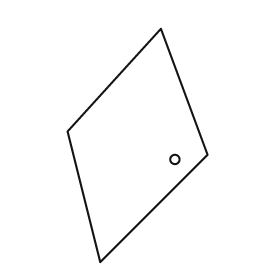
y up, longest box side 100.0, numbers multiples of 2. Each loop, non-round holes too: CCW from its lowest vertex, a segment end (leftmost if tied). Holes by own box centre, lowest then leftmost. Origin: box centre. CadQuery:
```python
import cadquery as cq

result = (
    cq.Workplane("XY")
    .moveTo(-16.0, -50.0)
    .lineTo(30.0, -4.0)
    .lineTo(10.0, 50.0)
    .lineTo(-30.0, 6.0)
    .close()
    .moveTo(16.0, -6.0)
    .circle(2.0)
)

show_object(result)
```